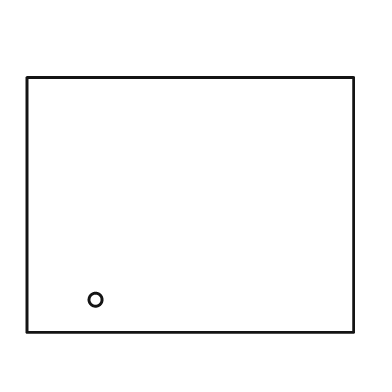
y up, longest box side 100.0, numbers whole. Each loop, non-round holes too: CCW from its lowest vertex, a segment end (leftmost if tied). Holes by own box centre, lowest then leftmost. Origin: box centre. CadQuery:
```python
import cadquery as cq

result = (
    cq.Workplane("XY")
    .moveTo(-50.0, -39.0)
    .lineTo(50.0, -39.0)
    .lineTo(50.0, 39.0)
    .lineTo(-50.0, 39.0)
    .close()
    .moveTo(-29.0, -29.0)
    .circle(2.0)
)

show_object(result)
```